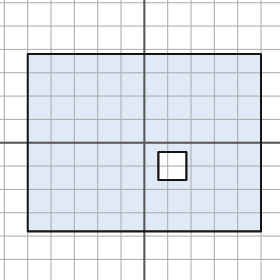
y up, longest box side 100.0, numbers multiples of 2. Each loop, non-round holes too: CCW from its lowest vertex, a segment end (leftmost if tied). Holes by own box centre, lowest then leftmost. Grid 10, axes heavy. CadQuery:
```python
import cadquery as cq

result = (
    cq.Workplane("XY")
    .moveTo(-50.0, -38.0)
    .lineTo(50.0, -38.0)
    .lineTo(50.0, 38.0)
    .lineTo(-50.0, 38.0)
    .close()
    .moveTo(6.0, -16.0)
    .lineTo(18.0, -16.0)
    .lineTo(18.0, -4.0)
    .lineTo(6.0, -4.0)
    .close()
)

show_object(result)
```